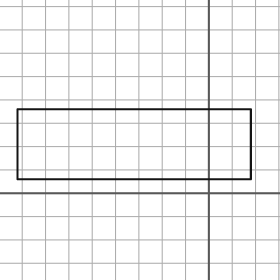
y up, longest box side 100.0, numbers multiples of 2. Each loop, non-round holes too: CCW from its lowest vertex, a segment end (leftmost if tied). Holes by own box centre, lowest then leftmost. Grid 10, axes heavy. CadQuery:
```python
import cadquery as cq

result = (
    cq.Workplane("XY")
    .moveTo(-82.0, 6.0)
    .lineTo(18.0, 6.0)
    .lineTo(18.0, 36.0)
    .lineTo(-82.0, 36.0)
    .close()
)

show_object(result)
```